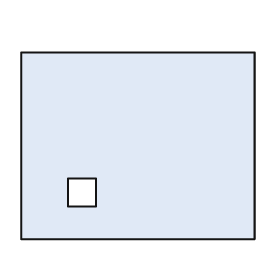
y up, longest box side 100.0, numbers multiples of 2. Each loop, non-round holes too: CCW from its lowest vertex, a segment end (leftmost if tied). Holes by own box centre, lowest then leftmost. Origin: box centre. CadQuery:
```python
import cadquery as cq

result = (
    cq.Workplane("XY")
    .moveTo(-50.0, -40.0)
    .lineTo(50.0, -40.0)
    .lineTo(50.0, 40.0)
    .lineTo(-50.0, 40.0)
    .close()
    .moveTo(-30.0, -26.0)
    .lineTo(-18.0, -26.0)
    .lineTo(-18.0, -14.0)
    .lineTo(-30.0, -14.0)
    .close()
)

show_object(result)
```